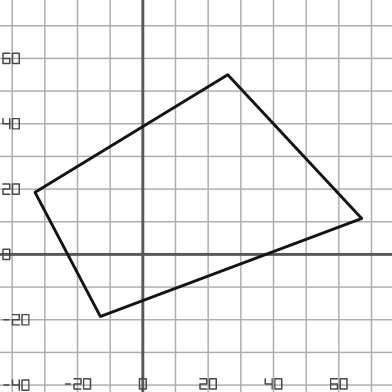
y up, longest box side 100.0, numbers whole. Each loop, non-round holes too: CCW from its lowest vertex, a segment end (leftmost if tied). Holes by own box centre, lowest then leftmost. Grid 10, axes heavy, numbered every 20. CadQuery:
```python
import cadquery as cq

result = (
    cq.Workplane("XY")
    .moveTo(-13.0, -19.0)
    .lineTo(67.0, 11.0)
    .lineTo(26.0, 55.0)
    .lineTo(-33.0, 19.0)
    .close()
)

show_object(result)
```